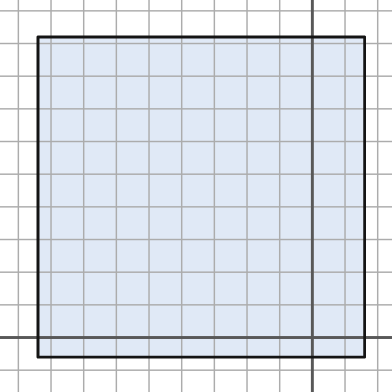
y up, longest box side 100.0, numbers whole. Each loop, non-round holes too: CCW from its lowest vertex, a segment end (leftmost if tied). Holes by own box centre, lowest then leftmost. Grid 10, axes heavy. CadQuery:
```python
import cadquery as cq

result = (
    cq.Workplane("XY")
    .moveTo(-84.0, -6.0)
    .lineTo(16.0, -6.0)
    .lineTo(16.0, 92.0)
    .lineTo(-84.0, 92.0)
    .close()
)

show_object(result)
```